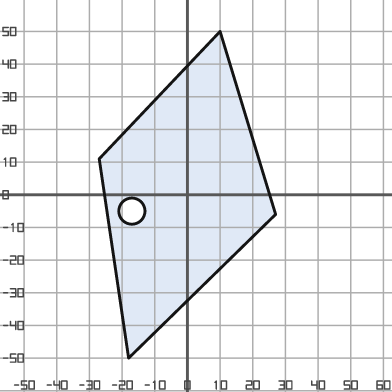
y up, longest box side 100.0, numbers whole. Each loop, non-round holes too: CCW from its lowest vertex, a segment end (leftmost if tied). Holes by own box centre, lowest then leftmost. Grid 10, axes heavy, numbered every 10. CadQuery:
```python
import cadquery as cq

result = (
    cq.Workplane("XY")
    .moveTo(-18.0, -50.0)
    .lineTo(27.0, -6.0)
    .lineTo(10.0, 50.0)
    .lineTo(-27.0, 11.0)
    .close()
    .moveTo(-17.0, -5.0)
    .circle(4.0)
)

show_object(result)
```